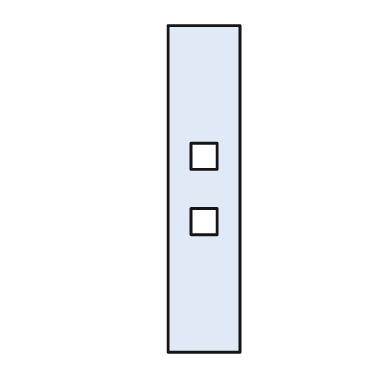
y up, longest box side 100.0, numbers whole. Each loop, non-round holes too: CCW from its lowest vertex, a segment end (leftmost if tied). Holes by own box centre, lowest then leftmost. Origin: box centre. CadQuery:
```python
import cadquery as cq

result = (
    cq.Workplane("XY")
    .moveTo(-11.0, -50.0)
    .lineTo(11.0, -50.0)
    .lineTo(11.0, 50.0)
    .lineTo(-11.0, 50.0)
    .close()
    .moveTo(-4.0, -14.0)
    .lineTo(4.0, -14.0)
    .lineTo(4.0, -6.0)
    .lineTo(-4.0, -6.0)
    .close()
    .moveTo(-4.0, 6.0)
    .lineTo(4.0, 6.0)
    .lineTo(4.0, 14.0)
    .lineTo(-4.0, 14.0)
    .close()
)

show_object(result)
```